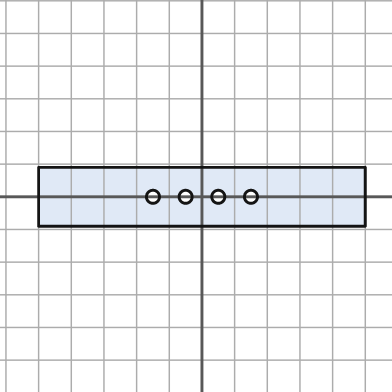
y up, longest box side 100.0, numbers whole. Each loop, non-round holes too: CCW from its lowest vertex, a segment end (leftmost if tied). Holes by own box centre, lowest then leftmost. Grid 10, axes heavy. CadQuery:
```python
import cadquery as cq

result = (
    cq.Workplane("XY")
    .moveTo(-50.0, -9.0)
    .lineTo(50.0, -9.0)
    .lineTo(50.0, 9.0)
    .lineTo(-50.0, 9.0)
    .close()
    .moveTo(-15.0, 0.0)
    .circle(2.0)
    .moveTo(-5.0, 0.0)
    .circle(2.0)
    .moveTo(5.0, 0.0)
    .circle(2.0)
    .moveTo(15.0, 0.0)
    .circle(2.0)
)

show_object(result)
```